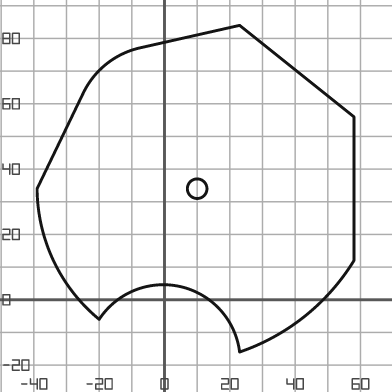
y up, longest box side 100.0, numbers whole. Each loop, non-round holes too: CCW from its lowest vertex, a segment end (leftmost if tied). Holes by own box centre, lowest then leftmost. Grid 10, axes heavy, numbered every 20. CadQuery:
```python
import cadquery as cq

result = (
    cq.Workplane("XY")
    .moveTo(23.0, -16.0)
    .threePointArc((43.0, -5.0), (58.0, 12.0))
    .lineTo(58.0, 56.0)
    .lineTo(23.0, 84.0)
    .lineTo(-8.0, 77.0)
    .threePointArc((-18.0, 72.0), (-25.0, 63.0))
    .lineTo(-39.0, 34.0)
    .threePointArc((-34.0, 12.0), (-20.0, -6.0))
    .threePointArc((5.0, 4.0), (23.0, -16.0))
    .close()
    .moveTo(10.0, 34.0)
    .circle(3.0)
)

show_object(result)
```